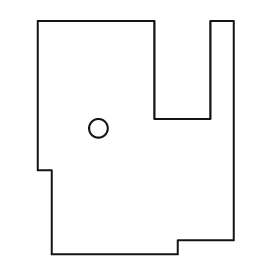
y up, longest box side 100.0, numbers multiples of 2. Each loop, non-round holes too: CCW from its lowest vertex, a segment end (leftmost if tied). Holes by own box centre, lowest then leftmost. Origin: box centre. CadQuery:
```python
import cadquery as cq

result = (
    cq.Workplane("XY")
    .moveTo(-36.0, -50.0)
    .lineTo(18.0, -50.0)
    .lineTo(18.0, -44.0)
    .lineTo(42.0, -44.0)
    .lineTo(42.0, 50.0)
    .lineTo(32.0, 50.0)
    .lineTo(32.0, 8.0)
    .lineTo(8.0, 8.0)
    .lineTo(8.0, 50.0)
    .lineTo(-42.0, 50.0)
    .lineTo(-42.0, -14.0)
    .lineTo(-36.0, -14.0)
    .close()
    .moveTo(-16.0, 4.0)
    .circle(4.0)
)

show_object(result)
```